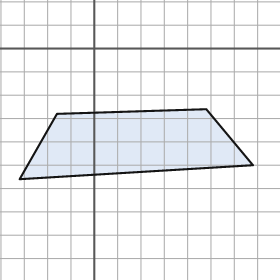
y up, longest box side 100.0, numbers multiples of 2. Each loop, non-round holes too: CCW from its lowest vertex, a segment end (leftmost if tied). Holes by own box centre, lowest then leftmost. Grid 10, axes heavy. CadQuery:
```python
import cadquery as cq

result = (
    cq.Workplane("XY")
    .moveTo(-32.0, -56.0)
    .lineTo(68.0, -50.0)
    .lineTo(48.0, -26.0)
    .lineTo(-16.0, -28.0)
    .close()
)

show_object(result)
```